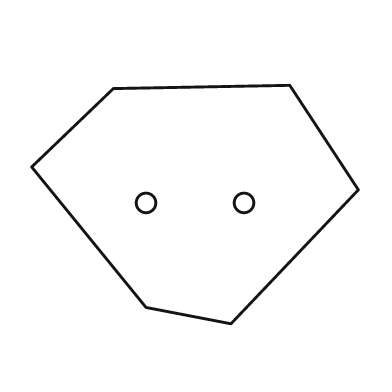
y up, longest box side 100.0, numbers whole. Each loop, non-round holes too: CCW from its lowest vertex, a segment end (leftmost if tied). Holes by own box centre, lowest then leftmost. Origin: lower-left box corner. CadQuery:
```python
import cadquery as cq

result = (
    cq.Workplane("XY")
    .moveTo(61.0, 0.0)
    .lineTo(100.0, 41.0)
    .lineTo(79.0, 73.0)
    .lineTo(25.0, 72.0)
    .lineTo(0.0, 48.0)
    .lineTo(35.0, 5.0)
    .close()
    .moveTo(35.0, 37.0)
    .circle(3.0)
    .moveTo(65.0, 37.0)
    .circle(3.0)
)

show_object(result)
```